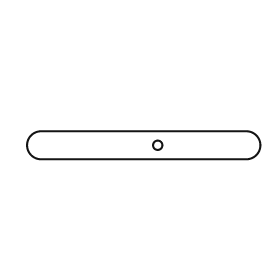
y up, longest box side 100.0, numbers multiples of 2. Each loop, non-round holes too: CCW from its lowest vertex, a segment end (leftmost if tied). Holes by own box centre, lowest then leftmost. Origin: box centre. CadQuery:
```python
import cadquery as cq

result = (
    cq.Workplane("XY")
    .moveTo(-44.0, -6.0)
    .lineTo(44.0, -6.0)
    .threePointArc((50.0, 0.0), (44.0, 6.0))
    .lineTo(-44.0, 6.0)
    .threePointArc((-50.0, 0.0), (-44.0, -6.0))
    .close()
    .moveTo(6.0, 0.0)
    .circle(2.0)
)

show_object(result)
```